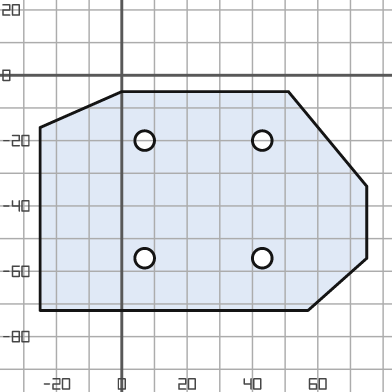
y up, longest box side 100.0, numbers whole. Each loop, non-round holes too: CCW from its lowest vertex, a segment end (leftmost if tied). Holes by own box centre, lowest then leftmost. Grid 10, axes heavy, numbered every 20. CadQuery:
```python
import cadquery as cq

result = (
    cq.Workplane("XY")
    .moveTo(-25.0, -72.0)
    .lineTo(57.0, -72.0)
    .lineTo(75.0, -56.0)
    .lineTo(75.0, -34.0)
    .lineTo(51.0, -5.0)
    .lineTo(0.0, -5.0)
    .lineTo(-25.0, -16.0)
    .close()
    .moveTo(7.0, -56.0)
    .circle(3.0)
    .moveTo(43.0, -56.0)
    .circle(3.0)
    .moveTo(7.0, -20.0)
    .circle(3.0)
    .moveTo(43.0, -20.0)
    .circle(3.0)
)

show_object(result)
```